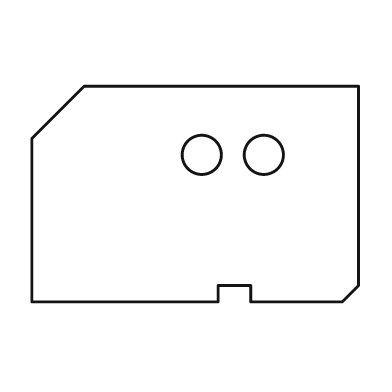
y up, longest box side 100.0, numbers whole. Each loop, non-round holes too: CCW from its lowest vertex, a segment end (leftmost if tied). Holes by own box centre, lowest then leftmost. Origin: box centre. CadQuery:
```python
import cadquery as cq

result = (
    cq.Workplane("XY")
    .moveTo(-50.0, -33.0)
    .lineTo(7.0, -33.0)
    .lineTo(7.0, -28.0)
    .lineTo(17.0, -28.0)
    .lineTo(17.0, -33.0)
    .lineTo(45.0, -33.0)
    .lineTo(50.0, -28.0)
    .lineTo(50.0, 33.0)
    .lineTo(-34.0, 33.0)
    .lineTo(-50.0, 17.0)
    .close()
    .moveTo(2.0, 12.0)
    .circle(6.0)
    .moveTo(21.0, 12.0)
    .circle(6.0)
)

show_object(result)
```